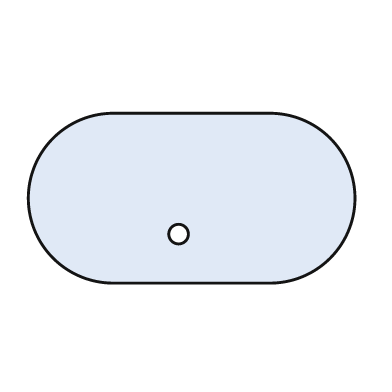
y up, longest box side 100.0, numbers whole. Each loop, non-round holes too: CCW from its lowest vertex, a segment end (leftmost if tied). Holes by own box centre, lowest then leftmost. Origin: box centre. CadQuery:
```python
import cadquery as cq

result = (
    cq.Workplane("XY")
    .moveTo(-24.0, -26.0)
    .lineTo(24.0, -26.0)
    .threePointArc((50.0, 0.0), (24.0, 26.0))
    .lineTo(-24.0, 26.0)
    .threePointArc((-50.0, 0.0), (-24.0, -26.0))
    .close()
    .moveTo(-4.0, -11.0)
    .circle(3.0)
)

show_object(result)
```